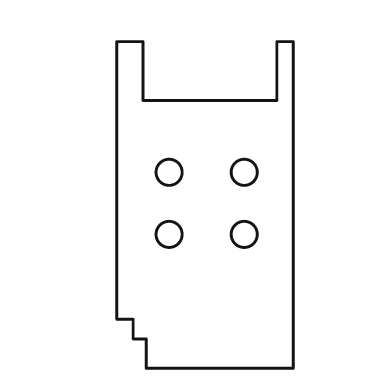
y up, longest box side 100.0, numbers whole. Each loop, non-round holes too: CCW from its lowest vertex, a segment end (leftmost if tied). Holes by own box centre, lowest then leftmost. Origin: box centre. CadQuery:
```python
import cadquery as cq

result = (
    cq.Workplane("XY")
    .moveTo(-18.0, -50.0)
    .lineTo(27.0, -50.0)
    .lineTo(27.0, 50.0)
    .lineTo(22.0, 50.0)
    .lineTo(22.0, 32.0)
    .lineTo(-19.0, 32.0)
    .lineTo(-19.0, 50.0)
    .lineTo(-27.0, 50.0)
    .lineTo(-27.0, -35.0)
    .lineTo(-22.0, -35.0)
    .lineTo(-22.0, -41.0)
    .lineTo(-18.0, -41.0)
    .close()
    .moveTo(-11.0, -9.0)
    .circle(4.0)
    .moveTo(12.0, -9.0)
    .circle(4.0)
    .moveTo(-11.0, 10.0)
    .circle(4.0)
    .moveTo(12.0, 10.0)
    .circle(4.0)
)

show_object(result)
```